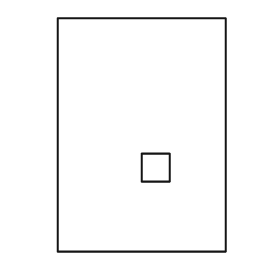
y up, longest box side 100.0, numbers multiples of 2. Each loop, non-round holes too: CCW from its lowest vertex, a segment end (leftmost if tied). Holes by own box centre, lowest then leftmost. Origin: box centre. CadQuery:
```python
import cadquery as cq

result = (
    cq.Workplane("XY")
    .moveTo(-36.0, -50.0)
    .lineTo(36.0, -50.0)
    .lineTo(36.0, 50.0)
    .lineTo(-36.0, 50.0)
    .close()
    .moveTo(0.0, -20.0)
    .lineTo(12.0, -20.0)
    .lineTo(12.0, -8.0)
    .lineTo(0.0, -8.0)
    .close()
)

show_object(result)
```